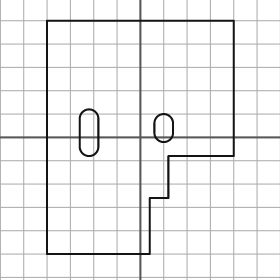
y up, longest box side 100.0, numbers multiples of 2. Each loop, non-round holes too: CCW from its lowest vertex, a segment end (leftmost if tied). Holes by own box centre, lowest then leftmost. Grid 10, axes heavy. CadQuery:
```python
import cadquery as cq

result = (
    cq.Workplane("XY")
    .moveTo(-40.0, -50.0)
    .lineTo(4.0, -50.0)
    .lineTo(4.0, -26.0)
    .lineTo(12.0, -26.0)
    .lineTo(12.0, -8.0)
    .lineTo(40.0, -8.0)
    .lineTo(40.0, 50.0)
    .lineTo(-40.0, 50.0)
    .close()
    .moveTo(-26.0, -4.0)
    .threePointArc((-22.0, -8.0), (-18.0, -4.0))
    .lineTo(-18.0, 8.0)
    .threePointArc((-22.0, 12.0), (-26.0, 8.0))
    .close()
    .moveTo(6.0, 2.0)
    .threePointArc((10.0, -2.0), (14.0, 2.0))
    .lineTo(14.0, 6.0)
    .threePointArc((10.0, 10.0), (6.0, 6.0))
    .close()
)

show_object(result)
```